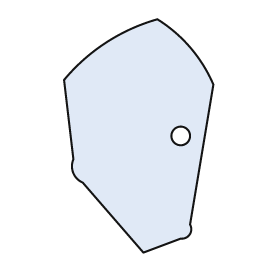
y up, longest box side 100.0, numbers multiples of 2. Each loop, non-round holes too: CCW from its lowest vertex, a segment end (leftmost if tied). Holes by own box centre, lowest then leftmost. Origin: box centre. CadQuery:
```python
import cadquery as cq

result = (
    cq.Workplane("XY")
    .moveTo(2.0, -50.0)
    .lineTo(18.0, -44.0)
    .threePointArc((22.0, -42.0), (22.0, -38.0))
    .lineTo(32.0, 22.0)
    .threePointArc((22.0, 38.0), (8.0, 50.0))
    .threePointArc((-14.0, 40.0), (-32.0, 24.0))
    .lineTo(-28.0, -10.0)
    .threePointArc((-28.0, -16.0), (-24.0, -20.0))
    .close()
    .moveTo(18.0, 0.0)
    .circle(4.0)
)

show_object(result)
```